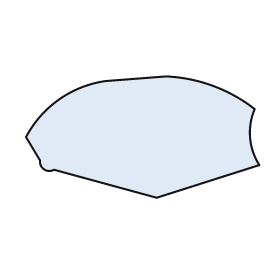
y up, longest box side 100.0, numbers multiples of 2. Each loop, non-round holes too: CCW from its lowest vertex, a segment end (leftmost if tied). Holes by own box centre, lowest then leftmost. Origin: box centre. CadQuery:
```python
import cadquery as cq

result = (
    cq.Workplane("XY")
    .moveTo(6.0, -26.0)
    .lineTo(50.0, -12.0)
    .threePointArc((46.0, 0.0), (48.0, 12.0))
    .threePointArc((30.0, 22.0), (10.0, 26.0))
    .lineTo(-16.0, 24.0)
    .threePointArc((-36.0, 16.0), (-50.0, 0.0))
    .lineTo(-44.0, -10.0)
    .threePointArc((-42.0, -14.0), (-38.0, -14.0))
    .close()
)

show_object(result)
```